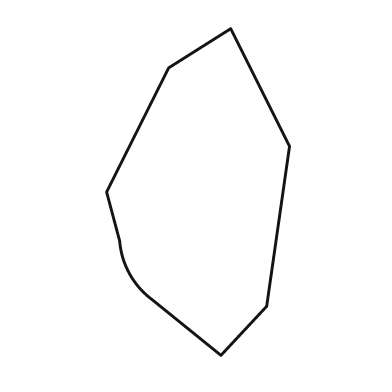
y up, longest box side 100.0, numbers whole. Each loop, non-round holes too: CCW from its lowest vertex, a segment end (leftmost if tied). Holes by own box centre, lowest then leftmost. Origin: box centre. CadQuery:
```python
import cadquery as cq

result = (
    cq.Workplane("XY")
    .moveTo(7.0, -50.0)
    .lineTo(21.0, -35.0)
    .lineTo(28.0, 14.0)
    .lineTo(10.0, 50.0)
    .lineTo(-9.0, 38.0)
    .lineTo(-28.0, 0.0)
    .lineTo(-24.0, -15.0)
    .threePointArc((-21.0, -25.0), (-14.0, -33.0))
    .close()
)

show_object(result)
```